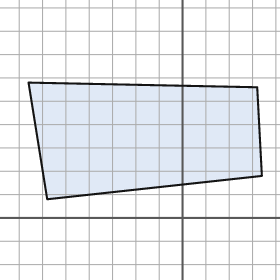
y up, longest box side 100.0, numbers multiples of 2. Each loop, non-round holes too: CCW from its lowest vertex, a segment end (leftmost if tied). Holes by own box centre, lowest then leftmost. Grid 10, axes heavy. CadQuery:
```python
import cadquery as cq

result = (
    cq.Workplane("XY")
    .moveTo(-58.0, 8.0)
    .lineTo(34.0, 18.0)
    .lineTo(32.0, 56.0)
    .lineTo(-66.0, 58.0)
    .close()
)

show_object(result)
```